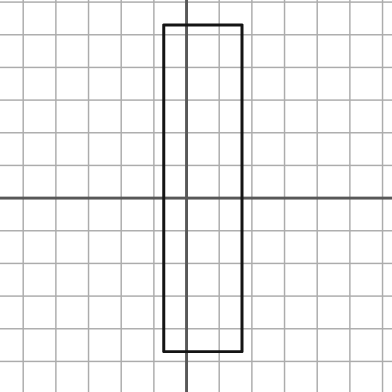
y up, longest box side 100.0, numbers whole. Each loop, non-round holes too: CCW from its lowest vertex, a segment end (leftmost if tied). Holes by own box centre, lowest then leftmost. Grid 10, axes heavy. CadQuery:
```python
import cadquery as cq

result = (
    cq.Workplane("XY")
    .moveTo(-7.0, -47.0)
    .lineTo(17.0, -47.0)
    .lineTo(17.0, 53.0)
    .lineTo(-7.0, 53.0)
    .close()
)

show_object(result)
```